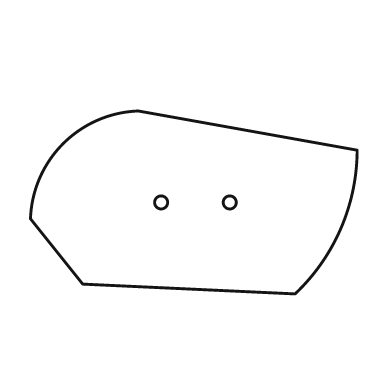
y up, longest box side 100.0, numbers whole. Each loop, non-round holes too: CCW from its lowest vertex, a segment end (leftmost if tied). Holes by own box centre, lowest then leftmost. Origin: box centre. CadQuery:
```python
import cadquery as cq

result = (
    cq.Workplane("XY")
    .moveTo(31.0, -28.0)
    .threePointArc((45.0, -8.0), (50.0, 16.0))
    .lineTo(-17.0, 28.0)
    .threePointArc((-40.0, 18.0), (-50.0, -5.0))
    .lineTo(-34.0, -25.0)
    .close()
    .moveTo(-10.0, 0.0)
    .circle(2.0)
    .moveTo(11.0, 0.0)
    .circle(2.0)
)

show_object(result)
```